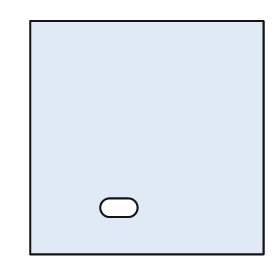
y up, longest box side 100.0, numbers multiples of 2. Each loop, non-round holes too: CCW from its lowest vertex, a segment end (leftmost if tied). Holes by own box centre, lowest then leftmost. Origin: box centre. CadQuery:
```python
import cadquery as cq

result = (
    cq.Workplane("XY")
    .moveTo(-50.0, -50.0)
    .lineTo(50.0, -50.0)
    .lineTo(50.0, 50.0)
    .lineTo(-50.0, 50.0)
    .close()
    .moveTo(-16.0, -34.0)
    .lineTo(-8.0, -34.0)
    .threePointArc((-4.0, -30.0), (-8.0, -26.0))
    .lineTo(-16.0, -26.0)
    .threePointArc((-20.0, -30.0), (-16.0, -34.0))
    .close()
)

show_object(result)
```